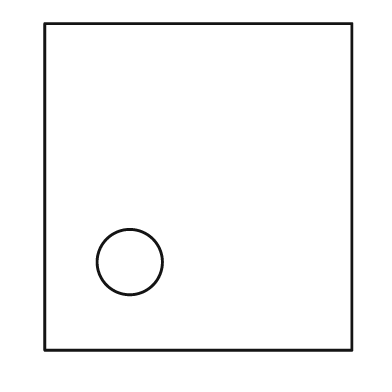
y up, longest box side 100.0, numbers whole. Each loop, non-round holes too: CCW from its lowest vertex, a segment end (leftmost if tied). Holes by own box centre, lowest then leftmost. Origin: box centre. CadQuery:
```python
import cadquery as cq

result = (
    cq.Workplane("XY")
    .moveTo(-47.0, -50.0)
    .lineTo(47.0, -50.0)
    .lineTo(47.0, 50.0)
    .lineTo(-47.0, 50.0)
    .close()
    .moveTo(-21.0, -23.0)
    .circle(10.0)
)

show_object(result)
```